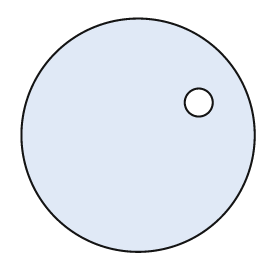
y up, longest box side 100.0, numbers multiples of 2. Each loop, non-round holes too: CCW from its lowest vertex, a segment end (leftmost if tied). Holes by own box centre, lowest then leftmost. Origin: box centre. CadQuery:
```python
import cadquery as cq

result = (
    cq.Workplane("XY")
    .moveTo(0.0, 0.0)
    .circle(50.0)
    .moveTo(26.0, 14.0)
    .circle(6.0)
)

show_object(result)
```